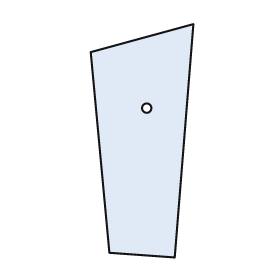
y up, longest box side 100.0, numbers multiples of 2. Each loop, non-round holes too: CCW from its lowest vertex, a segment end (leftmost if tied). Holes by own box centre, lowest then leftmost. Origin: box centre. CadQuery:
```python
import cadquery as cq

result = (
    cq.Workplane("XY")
    .moveTo(14.0, -50.0)
    .lineTo(22.0, 50.0)
    .lineTo(-22.0, 38.0)
    .lineTo(-14.0, -48.0)
    .close()
    .moveTo(2.0, 14.0)
    .circle(2.0)
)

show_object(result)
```